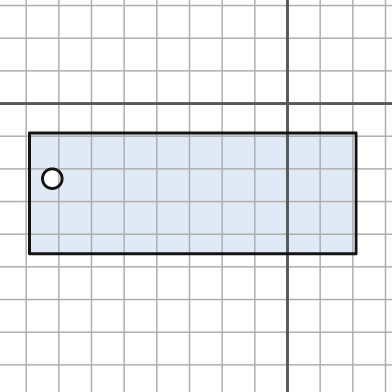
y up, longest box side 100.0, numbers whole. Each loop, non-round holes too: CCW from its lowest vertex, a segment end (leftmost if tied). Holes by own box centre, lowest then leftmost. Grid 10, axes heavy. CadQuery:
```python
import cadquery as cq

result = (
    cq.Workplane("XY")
    .moveTo(-79.0, -46.0)
    .lineTo(21.0, -46.0)
    .lineTo(21.0, -9.0)
    .lineTo(-79.0, -9.0)
    .close()
    .moveTo(-72.0, -23.0)
    .circle(3.0)
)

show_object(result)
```